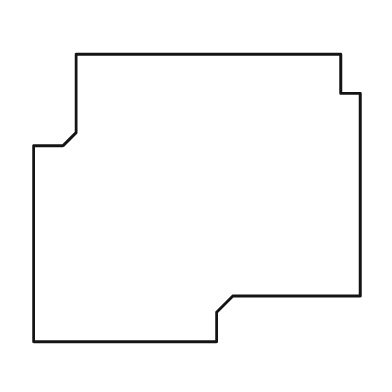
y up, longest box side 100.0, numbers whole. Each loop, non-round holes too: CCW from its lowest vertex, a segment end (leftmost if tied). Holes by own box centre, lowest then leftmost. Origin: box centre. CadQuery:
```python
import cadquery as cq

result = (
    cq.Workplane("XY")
    .moveTo(-50.0, -44.0)
    .lineTo(6.0, -44.0)
    .lineTo(6.0, -35.0)
    .lineTo(11.0, -30.0)
    .lineTo(50.0, -30.0)
    .lineTo(50.0, 32.0)
    .lineTo(44.0, 32.0)
    .lineTo(44.0, 44.0)
    .lineTo(-37.0, 44.0)
    .lineTo(-37.0, 20.0)
    .lineTo(-41.0, 16.0)
    .lineTo(-50.0, 16.0)
    .close()
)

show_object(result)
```